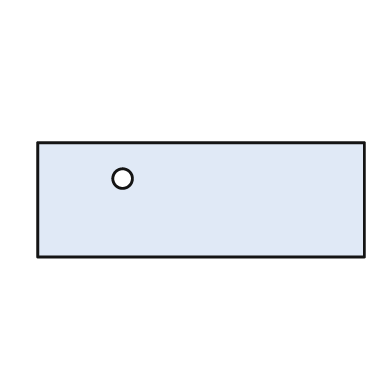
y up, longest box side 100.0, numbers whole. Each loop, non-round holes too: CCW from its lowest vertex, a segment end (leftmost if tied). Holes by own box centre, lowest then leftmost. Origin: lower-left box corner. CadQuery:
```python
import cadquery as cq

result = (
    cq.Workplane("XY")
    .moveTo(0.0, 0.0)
    .lineTo(100.0, 0.0)
    .lineTo(100.0, 35.0)
    .lineTo(0.0, 35.0)
    .close()
    .moveTo(26.0, 24.0)
    .circle(3.0)
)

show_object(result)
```